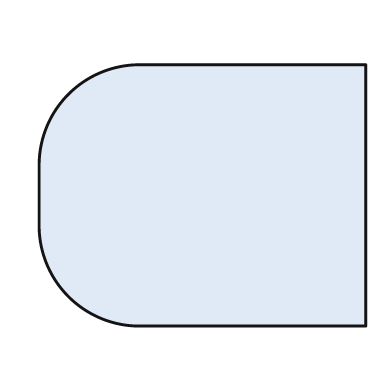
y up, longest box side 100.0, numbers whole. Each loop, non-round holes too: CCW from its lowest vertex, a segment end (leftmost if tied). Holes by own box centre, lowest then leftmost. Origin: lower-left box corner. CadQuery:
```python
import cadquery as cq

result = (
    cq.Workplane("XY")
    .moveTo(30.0, 0.0)
    .lineTo(100.0, 0.0)
    .lineTo(100.0, 80.0)
    .lineTo(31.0, 80.0)
    .threePointArc((9.0, 71.0), (0.0, 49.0))
    .lineTo(0.0, 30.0)
    .threePointArc((9.0, 9.0), (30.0, 0.0))
    .close()
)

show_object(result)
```